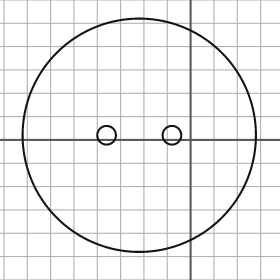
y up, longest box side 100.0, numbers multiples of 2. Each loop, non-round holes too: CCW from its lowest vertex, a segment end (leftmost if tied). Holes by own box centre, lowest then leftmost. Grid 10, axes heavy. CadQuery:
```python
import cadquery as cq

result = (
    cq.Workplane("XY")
    .moveTo(-22.0, 2.0)
    .circle(50.0)
    .moveTo(-36.0, 2.0)
    .circle(4.0)
    .moveTo(-8.0, 2.0)
    .circle(4.0)
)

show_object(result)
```